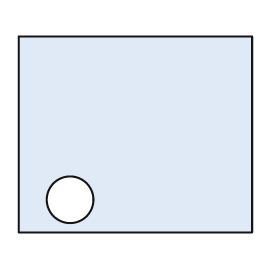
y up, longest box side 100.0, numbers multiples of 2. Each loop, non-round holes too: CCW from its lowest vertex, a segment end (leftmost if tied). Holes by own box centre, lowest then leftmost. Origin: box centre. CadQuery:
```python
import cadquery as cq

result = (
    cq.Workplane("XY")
    .moveTo(-50.0, -42.0)
    .lineTo(50.0, -42.0)
    .lineTo(50.0, 42.0)
    .lineTo(-50.0, 42.0)
    .close()
    .moveTo(-28.0, -28.0)
    .circle(10.0)
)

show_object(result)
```